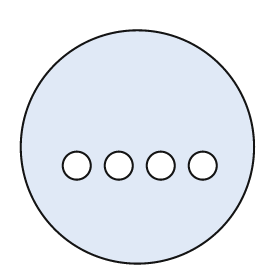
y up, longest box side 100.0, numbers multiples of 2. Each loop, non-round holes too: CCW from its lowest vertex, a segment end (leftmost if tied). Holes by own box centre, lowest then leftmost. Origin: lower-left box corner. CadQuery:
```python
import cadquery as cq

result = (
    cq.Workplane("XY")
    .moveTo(50.0, 50.0)
    .circle(50.0)
    .moveTo(24.0, 42.0)
    .circle(6.0)
    .moveTo(42.0, 42.0)
    .circle(6.0)
    .moveTo(60.0, 42.0)
    .circle(6.0)
    .moveTo(78.0, 42.0)
    .circle(6.0)
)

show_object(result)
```